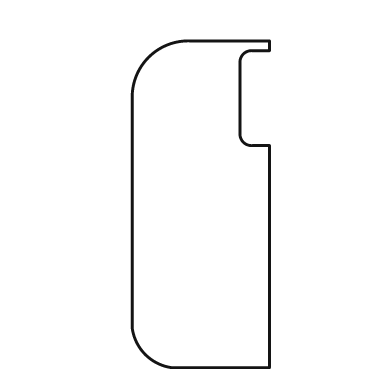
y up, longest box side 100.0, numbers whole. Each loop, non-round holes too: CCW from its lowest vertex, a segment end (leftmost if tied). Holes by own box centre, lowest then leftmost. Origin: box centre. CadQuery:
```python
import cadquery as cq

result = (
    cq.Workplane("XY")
    .moveTo(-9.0, -50.0)
    .lineTo(21.0, -50.0)
    .lineTo(21.0, 18.0)
    .lineTo(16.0, 18.0)
    .threePointArc((13.0, 19.0), (12.0, 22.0))
    .lineTo(12.0, 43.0)
    .threePointArc((13.0, 46.0), (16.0, 47.0))
    .lineTo(21.0, 47.0)
    .lineTo(21.0, 50.0)
    .lineTo(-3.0, 50.0)
    .threePointArc((-16.0, 45.0), (-21.0, 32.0))
    .lineTo(-21.0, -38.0)
    .threePointArc((-17.0, -46.0), (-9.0, -50.0))
    .close()
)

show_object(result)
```